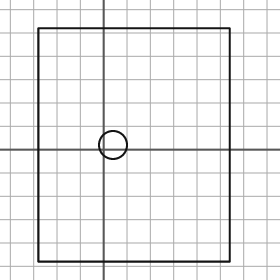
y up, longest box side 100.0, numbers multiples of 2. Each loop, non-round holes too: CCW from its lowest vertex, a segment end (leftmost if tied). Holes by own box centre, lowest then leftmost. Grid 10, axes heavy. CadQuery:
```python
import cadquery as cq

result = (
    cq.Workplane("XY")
    .moveTo(-28.0, -48.0)
    .lineTo(54.0, -48.0)
    .lineTo(54.0, 52.0)
    .lineTo(-28.0, 52.0)
    .close()
    .moveTo(4.0, 2.0)
    .circle(6.0)
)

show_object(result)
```